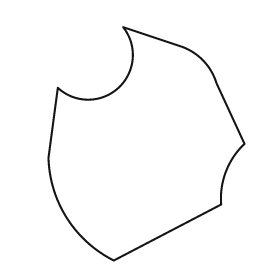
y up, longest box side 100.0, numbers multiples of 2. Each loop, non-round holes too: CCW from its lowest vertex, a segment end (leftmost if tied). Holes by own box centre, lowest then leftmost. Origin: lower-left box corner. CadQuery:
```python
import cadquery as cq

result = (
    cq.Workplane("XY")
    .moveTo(28.0, 0.0)
    .lineTo(74.0, 24.0)
    .threePointArc((76.0, 38.0), (84.0, 50.0))
    .lineTo(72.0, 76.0)
    .threePointArc((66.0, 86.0), (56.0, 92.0))
    .lineTo(32.0, 100.0)
    .threePointArc((30.0, 74.0), (4.0, 74.0))
    .lineTo(0.0, 44.0)
    .threePointArc((8.0, 18.0), (28.0, 0.0))
    .close()
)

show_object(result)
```